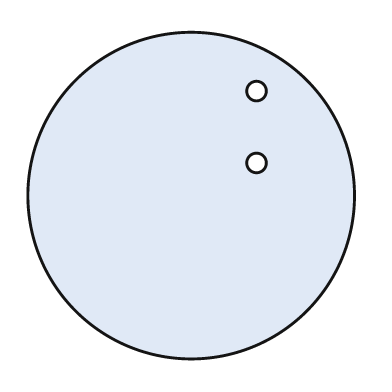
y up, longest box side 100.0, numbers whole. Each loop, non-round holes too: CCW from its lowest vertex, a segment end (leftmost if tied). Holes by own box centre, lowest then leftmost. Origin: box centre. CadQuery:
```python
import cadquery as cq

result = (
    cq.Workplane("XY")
    .moveTo(0.0, 0.0)
    .circle(50.0)
    .moveTo(20.0, 10.0)
    .circle(3.0)
    .moveTo(20.0, 32.0)
    .circle(3.0)
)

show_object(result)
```